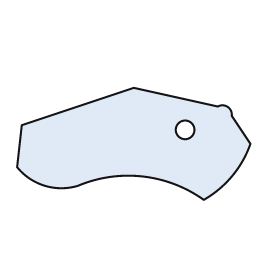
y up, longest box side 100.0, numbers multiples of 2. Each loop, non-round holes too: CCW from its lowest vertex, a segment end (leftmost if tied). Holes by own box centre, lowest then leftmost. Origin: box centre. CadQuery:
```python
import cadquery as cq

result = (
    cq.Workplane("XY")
    .moveTo(30.0, -24.0)
    .threePointArc((42.0, -14.0), (50.0, 0.0))
    .lineTo(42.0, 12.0)
    .threePointArc((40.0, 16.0), (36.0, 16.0))
    .lineTo(0.0, 24.0)
    .lineTo(-48.0, 8.0)
    .lineTo(-50.0, -10.0)
    .threePointArc((-38.0, -18.0), (-24.0, -18.0))
    .threePointArc((4.0, -14.0), (30.0, -24.0))
    .close()
    .moveTo(22.0, 6.0)
    .circle(4.0)
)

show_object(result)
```